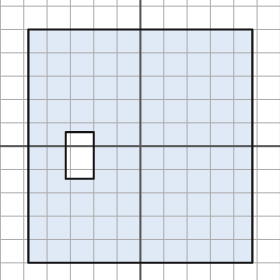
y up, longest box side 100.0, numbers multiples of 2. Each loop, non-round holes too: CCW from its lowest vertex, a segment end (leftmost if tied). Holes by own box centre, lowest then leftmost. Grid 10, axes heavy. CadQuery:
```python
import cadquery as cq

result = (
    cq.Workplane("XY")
    .moveTo(-48.0, -50.0)
    .lineTo(48.0, -50.0)
    .lineTo(48.0, 50.0)
    .lineTo(-48.0, 50.0)
    .close()
    .moveTo(-32.0, -14.0)
    .lineTo(-20.0, -14.0)
    .lineTo(-20.0, 6.0)
    .lineTo(-32.0, 6.0)
    .close()
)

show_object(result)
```